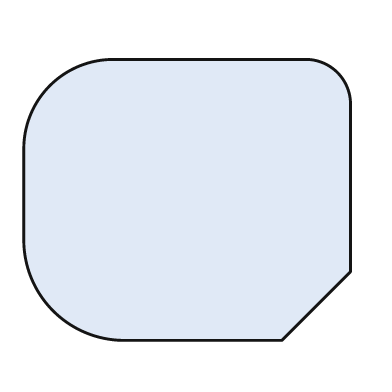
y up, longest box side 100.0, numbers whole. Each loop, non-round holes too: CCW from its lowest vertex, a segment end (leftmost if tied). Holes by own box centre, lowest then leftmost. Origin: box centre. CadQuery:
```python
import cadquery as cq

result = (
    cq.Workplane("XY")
    .moveTo(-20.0, -43.0)
    .lineTo(29.0, -43.0)
    .lineTo(50.0, -22.0)
    .lineTo(50.0, 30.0)
    .threePointArc((46.0, 39.0), (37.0, 43.0))
    .lineTo(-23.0, 43.0)
    .threePointArc((-42.0, 35.0), (-50.0, 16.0))
    .lineTo(-50.0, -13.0)
    .threePointArc((-41.0, -34.0), (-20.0, -43.0))
    .close()
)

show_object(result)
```